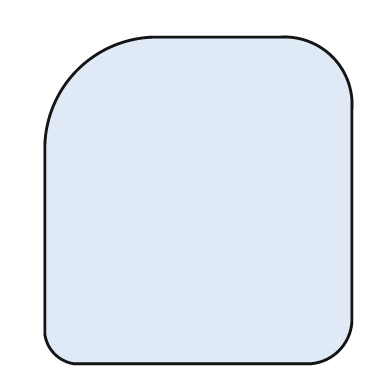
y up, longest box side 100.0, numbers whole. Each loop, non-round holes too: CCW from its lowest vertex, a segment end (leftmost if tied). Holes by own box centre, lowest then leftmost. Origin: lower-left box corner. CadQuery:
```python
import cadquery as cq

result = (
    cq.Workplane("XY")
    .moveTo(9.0, 0.0)
    .lineTo(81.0, 0.0)
    .threePointArc((90.0, 4.0), (94.0, 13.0))
    .lineTo(94.0, 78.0)
    .threePointArc((88.0, 94.0), (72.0, 100.0))
    .lineTo(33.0, 100.0)
    .threePointArc((10.0, 90.0), (0.0, 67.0))
    .lineTo(0.0, 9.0)
    .threePointArc((3.0, 3.0), (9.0, 0.0))
    .close()
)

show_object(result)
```